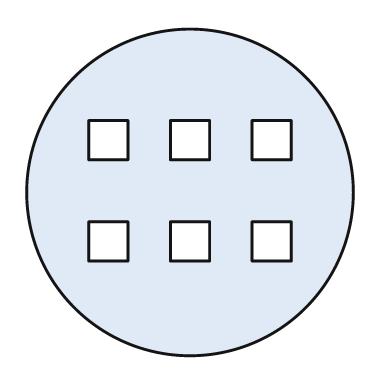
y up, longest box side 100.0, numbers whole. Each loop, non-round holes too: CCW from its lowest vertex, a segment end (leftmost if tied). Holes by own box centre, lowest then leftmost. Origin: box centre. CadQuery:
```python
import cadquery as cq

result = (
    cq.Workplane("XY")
    .moveTo(0.0, 0.0)
    .circle(50.0)
    .moveTo(-31.0, -21.0)
    .lineTo(-19.0, -21.0)
    .lineTo(-19.0, -9.0)
    .lineTo(-31.0, -9.0)
    .close()
    .moveTo(-6.0, -21.0)
    .lineTo(6.0, -21.0)
    .lineTo(6.0, -9.0)
    .lineTo(-6.0, -9.0)
    .close()
    .moveTo(19.0, -21.0)
    .lineTo(31.0, -21.0)
    .lineTo(31.0, -9.0)
    .lineTo(19.0, -9.0)
    .close()
    .moveTo(-31.0, 10.0)
    .lineTo(-19.0, 10.0)
    .lineTo(-19.0, 22.0)
    .lineTo(-31.0, 22.0)
    .close()
    .moveTo(-6.0, 10.0)
    .lineTo(6.0, 10.0)
    .lineTo(6.0, 22.0)
    .lineTo(-6.0, 22.0)
    .close()
    .moveTo(19.0, 10.0)
    .lineTo(31.0, 10.0)
    .lineTo(31.0, 22.0)
    .lineTo(19.0, 22.0)
    .close()
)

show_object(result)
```